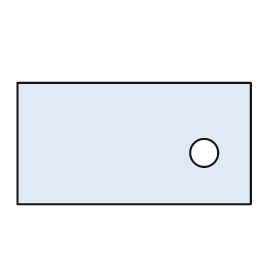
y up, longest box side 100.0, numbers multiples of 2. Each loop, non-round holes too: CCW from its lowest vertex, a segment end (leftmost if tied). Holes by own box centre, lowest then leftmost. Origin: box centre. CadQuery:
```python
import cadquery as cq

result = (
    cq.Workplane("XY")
    .moveTo(-50.0, -26.0)
    .lineTo(50.0, -26.0)
    .lineTo(50.0, 26.0)
    .lineTo(-50.0, 26.0)
    .close()
    .moveTo(30.0, -4.0)
    .circle(6.0)
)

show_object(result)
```